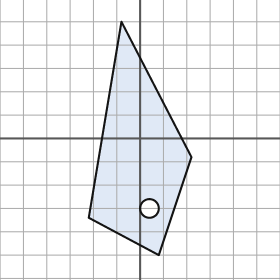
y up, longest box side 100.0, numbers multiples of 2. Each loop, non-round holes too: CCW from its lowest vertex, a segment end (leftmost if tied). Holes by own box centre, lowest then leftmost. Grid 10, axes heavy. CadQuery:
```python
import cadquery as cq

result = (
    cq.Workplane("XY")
    .moveTo(8.0, -50.0)
    .lineTo(22.0, -8.0)
    .lineTo(-8.0, 50.0)
    .lineTo(-22.0, -34.0)
    .close()
    .moveTo(4.0, -30.0)
    .circle(4.0)
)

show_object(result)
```